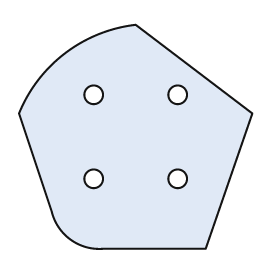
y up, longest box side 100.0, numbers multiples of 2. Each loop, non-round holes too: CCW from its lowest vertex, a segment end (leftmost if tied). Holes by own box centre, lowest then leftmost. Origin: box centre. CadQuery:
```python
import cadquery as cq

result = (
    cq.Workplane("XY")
    .moveTo(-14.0, -48.0)
    .lineTo(30.0, -48.0)
    .lineTo(50.0, 10.0)
    .lineTo(0.0, 48.0)
    .threePointArc((-30.0, 36.0), (-50.0, 10.0))
    .lineTo(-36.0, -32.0)
    .threePointArc((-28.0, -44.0), (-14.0, -48.0))
    .close()
    .moveTo(-18.0, -18.0)
    .circle(4.0)
    .moveTo(18.0, -18.0)
    .circle(4.0)
    .moveTo(-18.0, 18.0)
    .circle(4.0)
    .moveTo(18.0, 18.0)
    .circle(4.0)
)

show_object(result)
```